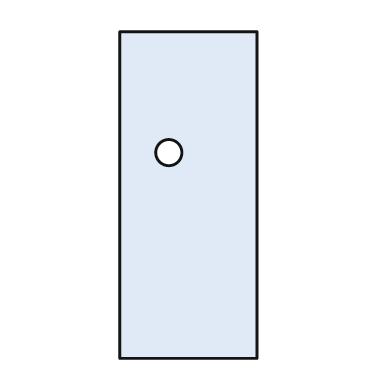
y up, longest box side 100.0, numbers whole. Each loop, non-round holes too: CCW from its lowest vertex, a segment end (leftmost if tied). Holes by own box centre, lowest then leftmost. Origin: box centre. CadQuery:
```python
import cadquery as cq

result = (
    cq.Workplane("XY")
    .moveTo(-21.0, -50.0)
    .lineTo(21.0, -50.0)
    .lineTo(21.0, 50.0)
    .lineTo(-21.0, 50.0)
    .close()
    .moveTo(-6.0, 13.0)
    .circle(4.0)
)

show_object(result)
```